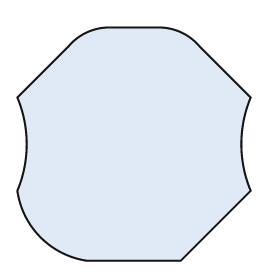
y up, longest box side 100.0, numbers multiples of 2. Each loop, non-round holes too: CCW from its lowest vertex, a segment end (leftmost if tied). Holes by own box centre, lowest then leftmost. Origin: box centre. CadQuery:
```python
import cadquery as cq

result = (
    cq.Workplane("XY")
    .moveTo(-20.0, -50.0)
    .lineTo(20.0, -50.0)
    .lineTo(50.0, -20.0)
    .threePointArc((46.0, 0.0), (50.0, 20.0))
    .lineTo(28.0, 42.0)
    .threePointArc((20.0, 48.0), (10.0, 50.0))
    .lineTo(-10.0, 50.0)
    .threePointArc((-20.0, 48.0), (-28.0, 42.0))
    .lineTo(-50.0, 20.0)
    .threePointArc((-46.0, 0.0), (-50.0, -20.0))
    .threePointArc((-40.0, -40.0), (-20.0, -50.0))
    .close()
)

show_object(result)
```